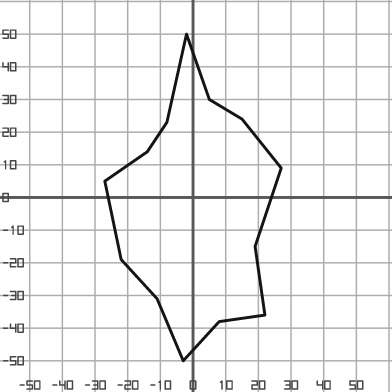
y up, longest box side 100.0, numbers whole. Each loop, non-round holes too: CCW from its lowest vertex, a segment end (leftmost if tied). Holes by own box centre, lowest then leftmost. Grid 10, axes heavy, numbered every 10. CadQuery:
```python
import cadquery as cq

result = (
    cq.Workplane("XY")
    .moveTo(-3.0, -50.0)
    .lineTo(8.0, -38.0)
    .lineTo(22.0, -36.0)
    .lineTo(19.0, -15.0)
    .lineTo(27.0, 9.0)
    .lineTo(15.0, 24.0)
    .lineTo(5.0, 30.0)
    .lineTo(-2.0, 50.0)
    .lineTo(-8.0, 23.0)
    .lineTo(-14.0, 14.0)
    .lineTo(-27.0, 5.0)
    .lineTo(-22.0, -19.0)
    .lineTo(-11.0, -31.0)
    .close()
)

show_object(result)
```